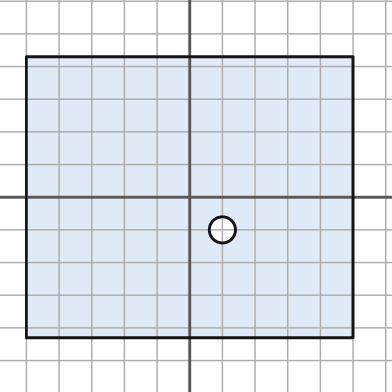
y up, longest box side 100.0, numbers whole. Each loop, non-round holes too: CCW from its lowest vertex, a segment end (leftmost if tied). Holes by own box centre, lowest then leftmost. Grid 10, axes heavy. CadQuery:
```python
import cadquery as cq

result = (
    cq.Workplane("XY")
    .moveTo(-50.0, -43.0)
    .lineTo(50.0, -43.0)
    .lineTo(50.0, 43.0)
    .lineTo(-50.0, 43.0)
    .close()
    .moveTo(10.0, -10.0)
    .circle(4.0)
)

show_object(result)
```